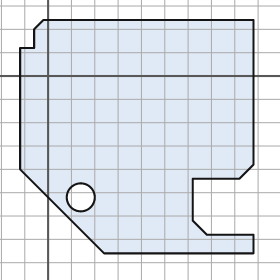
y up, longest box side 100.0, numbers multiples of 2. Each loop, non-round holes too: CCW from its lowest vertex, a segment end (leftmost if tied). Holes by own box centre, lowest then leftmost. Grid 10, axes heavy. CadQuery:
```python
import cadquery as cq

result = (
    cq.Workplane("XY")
    .moveTo(24.0, -76.0)
    .lineTo(88.0, -76.0)
    .lineTo(88.0, -68.0)
    .lineTo(68.0, -68.0)
    .lineTo(62.0, -62.0)
    .lineTo(62.0, -44.0)
    .lineTo(82.0, -44.0)
    .lineTo(88.0, -38.0)
    .lineTo(88.0, 24.0)
    .lineTo(-2.0, 24.0)
    .lineTo(-6.0, 20.0)
    .lineTo(-6.0, 12.0)
    .lineTo(-12.0, 12.0)
    .lineTo(-12.0, -40.0)
    .close()
    .moveTo(14.0, -52.0)
    .circle(6.0)
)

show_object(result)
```